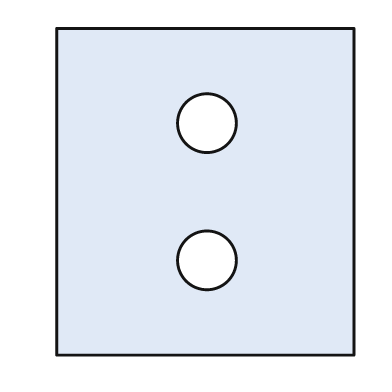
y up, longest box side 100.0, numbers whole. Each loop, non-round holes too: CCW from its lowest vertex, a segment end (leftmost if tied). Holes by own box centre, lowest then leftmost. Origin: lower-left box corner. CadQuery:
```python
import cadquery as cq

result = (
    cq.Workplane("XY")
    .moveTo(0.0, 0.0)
    .lineTo(91.0, 0.0)
    .lineTo(91.0, 100.0)
    .lineTo(0.0, 100.0)
    .close()
    .moveTo(46.0, 29.0)
    .circle(9.0)
    .moveTo(46.0, 71.0)
    .circle(9.0)
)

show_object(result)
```